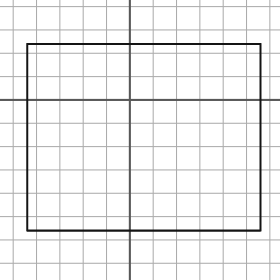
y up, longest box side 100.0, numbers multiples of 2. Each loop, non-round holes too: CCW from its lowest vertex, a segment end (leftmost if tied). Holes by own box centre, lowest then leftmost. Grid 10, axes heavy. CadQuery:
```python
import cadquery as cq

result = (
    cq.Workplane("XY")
    .moveTo(-44.0, -56.0)
    .lineTo(56.0, -56.0)
    .lineTo(56.0, 24.0)
    .lineTo(-44.0, 24.0)
    .close()
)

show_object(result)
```